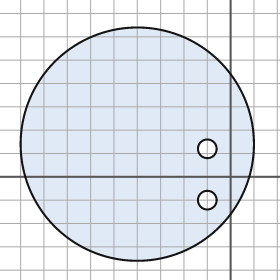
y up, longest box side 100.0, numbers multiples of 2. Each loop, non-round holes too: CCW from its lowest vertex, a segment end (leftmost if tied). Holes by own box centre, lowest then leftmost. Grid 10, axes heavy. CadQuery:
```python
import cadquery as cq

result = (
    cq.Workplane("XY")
    .moveTo(-40.0, 14.0)
    .circle(50.0)
    .moveTo(-10.0, -10.0)
    .circle(4.0)
    .moveTo(-10.0, 12.0)
    .circle(4.0)
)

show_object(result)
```